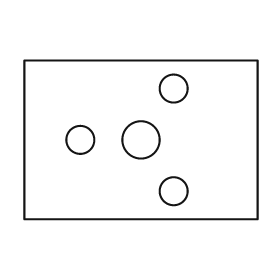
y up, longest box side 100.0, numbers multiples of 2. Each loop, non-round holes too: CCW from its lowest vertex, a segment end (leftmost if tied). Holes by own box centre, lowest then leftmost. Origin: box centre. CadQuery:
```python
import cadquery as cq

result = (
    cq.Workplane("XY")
    .moveTo(-50.0, -34.0)
    .lineTo(50.0, -34.0)
    .lineTo(50.0, 34.0)
    .lineTo(-50.0, 34.0)
    .close()
    .moveTo(14.0, -22.0)
    .circle(6.0)
    .moveTo(-26.0, 0.0)
    .circle(6.0)
    .moveTo(0.0, 0.0)
    .circle(8.0)
    .moveTo(14.0, 22.0)
    .circle(6.0)
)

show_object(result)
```